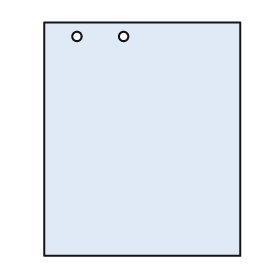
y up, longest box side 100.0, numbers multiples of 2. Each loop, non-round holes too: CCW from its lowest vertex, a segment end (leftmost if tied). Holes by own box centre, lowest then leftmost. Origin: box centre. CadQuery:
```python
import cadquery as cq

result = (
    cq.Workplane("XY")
    .moveTo(-42.0, -50.0)
    .lineTo(42.0, -50.0)
    .lineTo(42.0, 50.0)
    .lineTo(-42.0, 50.0)
    .close()
    .moveTo(-28.0, 44.0)
    .circle(2.0)
    .moveTo(-8.0, 44.0)
    .circle(2.0)
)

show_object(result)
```